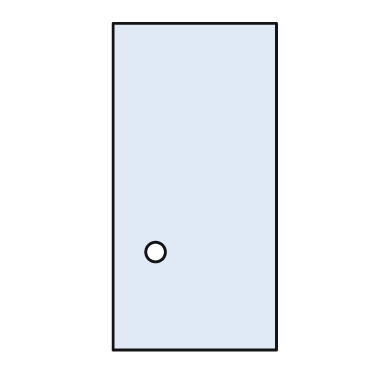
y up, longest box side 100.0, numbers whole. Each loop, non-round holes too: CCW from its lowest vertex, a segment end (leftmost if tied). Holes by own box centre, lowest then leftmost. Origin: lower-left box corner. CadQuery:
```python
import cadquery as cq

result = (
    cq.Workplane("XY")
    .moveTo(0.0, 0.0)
    .lineTo(50.0, 0.0)
    .lineTo(50.0, 100.0)
    .lineTo(0.0, 100.0)
    .close()
    .moveTo(13.0, 30.0)
    .circle(3.0)
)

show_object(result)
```